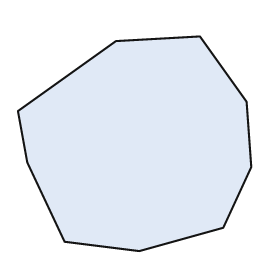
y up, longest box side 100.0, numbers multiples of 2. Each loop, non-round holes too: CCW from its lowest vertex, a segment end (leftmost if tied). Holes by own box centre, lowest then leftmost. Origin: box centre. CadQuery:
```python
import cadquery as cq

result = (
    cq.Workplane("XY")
    .moveTo(2.0, -46.0)
    .lineTo(38.0, -36.0)
    .lineTo(50.0, -10.0)
    .lineTo(48.0, 18.0)
    .lineTo(28.0, 46.0)
    .lineTo(-8.0, 44.0)
    .lineTo(-50.0, 14.0)
    .lineTo(-46.0, -8.0)
    .lineTo(-30.0, -42.0)
    .close()
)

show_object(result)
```